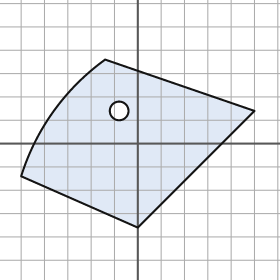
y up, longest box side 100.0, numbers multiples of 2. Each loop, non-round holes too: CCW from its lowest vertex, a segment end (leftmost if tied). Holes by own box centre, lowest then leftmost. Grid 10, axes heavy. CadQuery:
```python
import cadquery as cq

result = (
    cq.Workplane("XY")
    .moveTo(0.0, -36.0)
    .lineTo(50.0, 14.0)
    .lineTo(-14.0, 36.0)
    .threePointArc((-36.0, 14.0), (-50.0, -14.0))
    .close()
    .moveTo(-8.0, 14.0)
    .circle(4.0)
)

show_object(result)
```